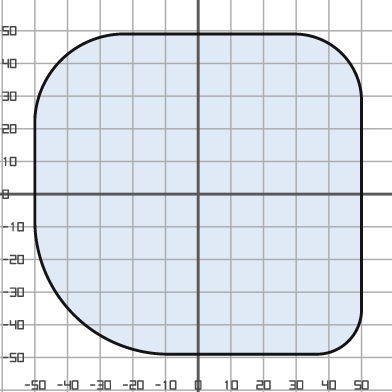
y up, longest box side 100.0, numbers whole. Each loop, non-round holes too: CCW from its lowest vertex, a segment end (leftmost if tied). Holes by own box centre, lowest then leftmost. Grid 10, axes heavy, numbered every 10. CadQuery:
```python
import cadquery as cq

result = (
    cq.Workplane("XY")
    .moveTo(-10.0, -49.0)
    .lineTo(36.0, -49.0)
    .threePointArc((46.0, -45.0), (50.0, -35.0))
    .lineTo(50.0, 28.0)
    .threePointArc((44.0, 43.0), (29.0, 49.0))
    .lineTo(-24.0, 49.0)
    .threePointArc((-42.0, 41.0), (-50.0, 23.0))
    .lineTo(-50.0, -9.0)
    .threePointArc((-38.0, -37.0), (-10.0, -49.0))
    .close()
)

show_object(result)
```